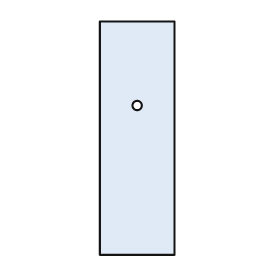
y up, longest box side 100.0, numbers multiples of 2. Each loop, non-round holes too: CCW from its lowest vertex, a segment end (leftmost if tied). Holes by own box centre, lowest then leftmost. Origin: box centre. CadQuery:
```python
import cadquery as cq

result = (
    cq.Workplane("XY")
    .moveTo(-16.0, -50.0)
    .lineTo(16.0, -50.0)
    .lineTo(16.0, 50.0)
    .lineTo(-16.0, 50.0)
    .close()
    .moveTo(0.0, 14.0)
    .circle(2.0)
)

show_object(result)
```